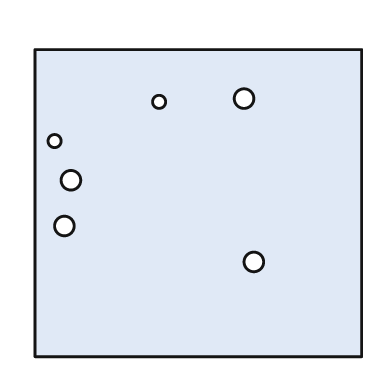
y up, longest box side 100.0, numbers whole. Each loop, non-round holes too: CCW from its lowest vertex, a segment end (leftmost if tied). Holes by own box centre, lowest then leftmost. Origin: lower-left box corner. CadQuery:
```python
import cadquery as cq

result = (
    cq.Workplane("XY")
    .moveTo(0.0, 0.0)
    .lineTo(100.0, 0.0)
    .lineTo(100.0, 94.0)
    .lineTo(0.0, 94.0)
    .close()
    .moveTo(67.0, 29.0)
    .circle(3.0)
    .moveTo(9.0, 40.0)
    .circle(3.0)
    .moveTo(11.0, 54.0)
    .circle(3.0)
    .moveTo(6.0, 66.0)
    .circle(2.0)
    .moveTo(38.0, 78.0)
    .circle(2.0)
    .moveTo(64.0, 79.0)
    .circle(3.0)
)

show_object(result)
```